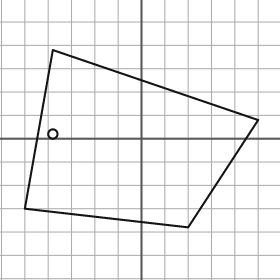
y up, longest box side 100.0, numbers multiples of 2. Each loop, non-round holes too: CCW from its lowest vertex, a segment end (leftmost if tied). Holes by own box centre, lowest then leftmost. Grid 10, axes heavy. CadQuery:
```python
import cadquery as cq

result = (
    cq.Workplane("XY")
    .moveTo(20.0, -38.0)
    .lineTo(50.0, 8.0)
    .lineTo(-38.0, 38.0)
    .lineTo(-50.0, -30.0)
    .close()
    .moveTo(-38.0, 2.0)
    .circle(2.0)
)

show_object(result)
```